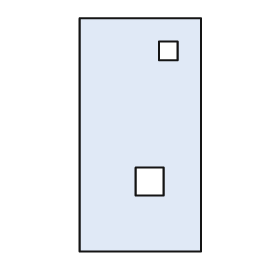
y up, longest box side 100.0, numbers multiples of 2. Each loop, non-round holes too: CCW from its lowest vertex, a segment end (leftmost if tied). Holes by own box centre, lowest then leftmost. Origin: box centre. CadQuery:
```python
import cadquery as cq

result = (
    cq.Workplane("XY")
    .moveTo(-26.0, -50.0)
    .lineTo(26.0, -50.0)
    .lineTo(26.0, 50.0)
    .lineTo(-26.0, 50.0)
    .close()
    .moveTo(-2.0, -26.0)
    .lineTo(10.0, -26.0)
    .lineTo(10.0, -14.0)
    .lineTo(-2.0, -14.0)
    .close()
    .moveTo(8.0, 32.0)
    .lineTo(16.0, 32.0)
    .lineTo(16.0, 40.0)
    .lineTo(8.0, 40.0)
    .close()
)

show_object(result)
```